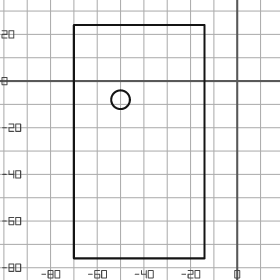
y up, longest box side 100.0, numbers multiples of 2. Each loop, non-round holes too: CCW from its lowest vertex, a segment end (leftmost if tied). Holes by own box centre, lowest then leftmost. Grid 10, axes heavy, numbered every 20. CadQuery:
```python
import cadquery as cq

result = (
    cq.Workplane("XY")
    .moveTo(-70.0, -76.0)
    .lineTo(-14.0, -76.0)
    .lineTo(-14.0, 24.0)
    .lineTo(-70.0, 24.0)
    .close()
    .moveTo(-50.0, -8.0)
    .circle(4.0)
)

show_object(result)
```